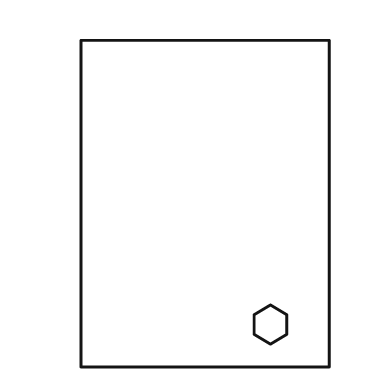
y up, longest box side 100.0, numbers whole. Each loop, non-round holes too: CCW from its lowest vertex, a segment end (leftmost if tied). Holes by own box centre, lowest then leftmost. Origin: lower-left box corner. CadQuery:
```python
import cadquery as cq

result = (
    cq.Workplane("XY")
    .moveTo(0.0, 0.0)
    .lineTo(76.0, 0.0)
    .lineTo(76.0, 100.0)
    .lineTo(0.0, 100.0)
    .close()
    .moveTo(58.0, 7.0)
    .lineTo(63.0, 10.0)
    .lineTo(63.0, 16.0)
    .lineTo(58.0, 19.0)
    .lineTo(53.0, 16.0)
    .lineTo(53.0, 10.0)
    .close()
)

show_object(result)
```